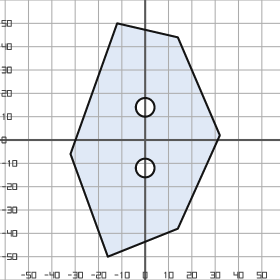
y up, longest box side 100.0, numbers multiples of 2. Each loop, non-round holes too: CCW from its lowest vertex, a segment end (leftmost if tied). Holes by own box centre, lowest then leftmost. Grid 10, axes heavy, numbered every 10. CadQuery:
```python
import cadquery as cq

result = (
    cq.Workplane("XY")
    .moveTo(-16.0, -50.0)
    .lineTo(14.0, -38.0)
    .lineTo(32.0, 2.0)
    .lineTo(14.0, 44.0)
    .lineTo(-12.0, 50.0)
    .lineTo(-32.0, -6.0)
    .close()
    .moveTo(0.0, -12.0)
    .circle(4.0)
    .moveTo(0.0, 14.0)
    .circle(4.0)
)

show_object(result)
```